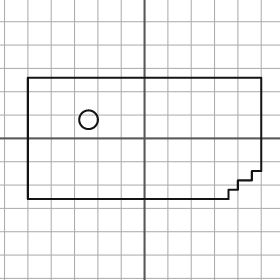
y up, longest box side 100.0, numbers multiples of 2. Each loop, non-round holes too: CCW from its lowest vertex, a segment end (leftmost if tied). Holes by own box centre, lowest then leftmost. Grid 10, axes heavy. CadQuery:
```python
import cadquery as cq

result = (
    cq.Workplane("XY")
    .moveTo(-50.0, -26.0)
    .lineTo(36.0, -26.0)
    .lineTo(36.0, -22.0)
    .lineTo(40.0, -22.0)
    .lineTo(40.0, -18.0)
    .lineTo(46.0, -18.0)
    .lineTo(46.0, -14.0)
    .lineTo(50.0, -14.0)
    .lineTo(50.0, 26.0)
    .lineTo(-50.0, 26.0)
    .close()
    .moveTo(-24.0, 8.0)
    .circle(4.0)
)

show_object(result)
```